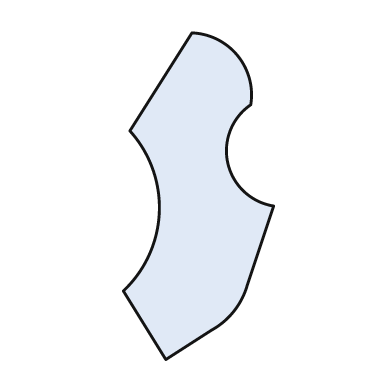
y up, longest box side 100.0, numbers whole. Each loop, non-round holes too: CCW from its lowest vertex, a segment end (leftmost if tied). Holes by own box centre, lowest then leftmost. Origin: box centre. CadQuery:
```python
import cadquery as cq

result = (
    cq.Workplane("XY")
    .moveTo(-10.0, -50.0)
    .lineTo(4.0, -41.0)
    .threePointArc((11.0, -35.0), (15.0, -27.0))
    .lineTo(23.0, -3.0)
    .threePointArc((9.0, 10.0), (16.0, 28.0))
    .threePointArc((12.0, 43.0), (-2.0, 50.0))
    .lineTo(-21.0, 20.0)
    .threePointArc((-12.0, -5.0), (-23.0, -29.0))
    .close()
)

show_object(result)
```